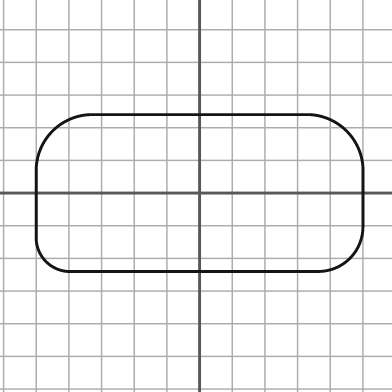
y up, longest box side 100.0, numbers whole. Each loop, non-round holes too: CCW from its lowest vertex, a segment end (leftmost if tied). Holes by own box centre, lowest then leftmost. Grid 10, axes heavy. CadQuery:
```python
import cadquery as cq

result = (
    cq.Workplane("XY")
    .moveTo(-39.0, -24.0)
    .lineTo(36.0, -24.0)
    .threePointArc((46.0, -20.0), (50.0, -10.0))
    .lineTo(50.0, 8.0)
    .threePointArc((45.0, 19.0), (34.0, 24.0))
    .lineTo(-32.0, 24.0)
    .threePointArc((-45.0, 19.0), (-50.0, 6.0))
    .lineTo(-50.0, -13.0)
    .threePointArc((-47.0, -21.0), (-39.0, -24.0))
    .close()
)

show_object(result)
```